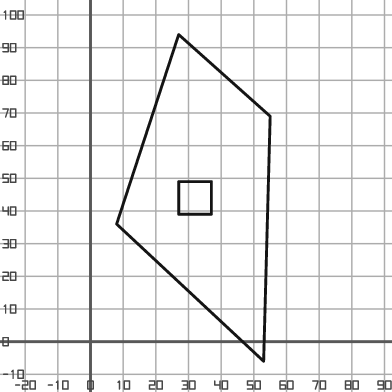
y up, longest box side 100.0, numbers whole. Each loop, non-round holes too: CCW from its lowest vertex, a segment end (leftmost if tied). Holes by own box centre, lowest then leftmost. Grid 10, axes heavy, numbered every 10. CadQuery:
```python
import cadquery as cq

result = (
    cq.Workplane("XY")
    .moveTo(53.0, -6.0)
    .lineTo(55.0, 69.0)
    .lineTo(27.0, 94.0)
    .lineTo(8.0, 36.0)
    .close()
    .moveTo(27.0, 39.0)
    .lineTo(37.0, 39.0)
    .lineTo(37.0, 49.0)
    .lineTo(27.0, 49.0)
    .close()
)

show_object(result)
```